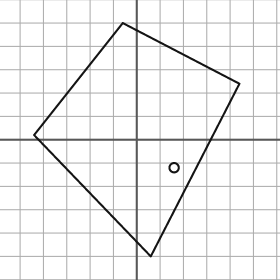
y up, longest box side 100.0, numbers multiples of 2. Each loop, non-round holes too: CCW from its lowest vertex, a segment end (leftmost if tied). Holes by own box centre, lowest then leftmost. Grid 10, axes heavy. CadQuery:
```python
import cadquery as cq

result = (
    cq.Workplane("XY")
    .moveTo(6.0, -50.0)
    .lineTo(44.0, 24.0)
    .lineTo(-6.0, 50.0)
    .lineTo(-44.0, 2.0)
    .close()
    .moveTo(16.0, -12.0)
    .circle(2.0)
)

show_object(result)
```